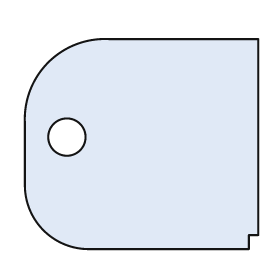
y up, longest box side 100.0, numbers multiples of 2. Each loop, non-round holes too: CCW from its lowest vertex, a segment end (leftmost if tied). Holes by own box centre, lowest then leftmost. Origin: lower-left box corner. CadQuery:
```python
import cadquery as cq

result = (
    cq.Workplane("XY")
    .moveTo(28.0, 0.0)
    .lineTo(96.0, 0.0)
    .lineTo(96.0, 6.0)
    .lineTo(100.0, 6.0)
    .lineTo(100.0, 90.0)
    .lineTo(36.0, 90.0)
    .threePointArc((10.0, 80.0), (0.0, 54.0))
    .lineTo(0.0, 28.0)
    .threePointArc((8.0, 8.0), (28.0, 0.0))
    .close()
    .moveTo(18.0, 48.0)
    .circle(8.0)
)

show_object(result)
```